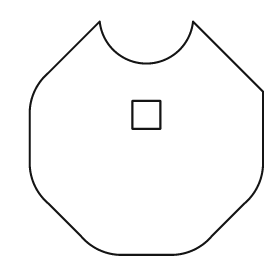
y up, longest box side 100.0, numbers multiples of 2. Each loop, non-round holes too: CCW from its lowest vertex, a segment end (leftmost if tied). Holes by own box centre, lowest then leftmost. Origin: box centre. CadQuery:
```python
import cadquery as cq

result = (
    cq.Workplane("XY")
    .moveTo(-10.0, -50.0)
    .lineTo(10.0, -50.0)
    .threePointArc((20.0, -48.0), (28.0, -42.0))
    .lineTo(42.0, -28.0)
    .threePointArc((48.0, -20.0), (50.0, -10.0))
    .lineTo(50.0, 20.0)
    .lineTo(20.0, 50.0)
    .threePointArc((0.0, 32.0), (-20.0, 50.0))
    .lineTo(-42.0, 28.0)
    .threePointArc((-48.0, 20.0), (-50.0, 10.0))
    .lineTo(-50.0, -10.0)
    .threePointArc((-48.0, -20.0), (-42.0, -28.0))
    .lineTo(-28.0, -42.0)
    .threePointArc((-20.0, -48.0), (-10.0, -50.0))
    .close()
    .moveTo(-6.0, 4.0)
    .lineTo(6.0, 4.0)
    .lineTo(6.0, 16.0)
    .lineTo(-6.0, 16.0)
    .close()
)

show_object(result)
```